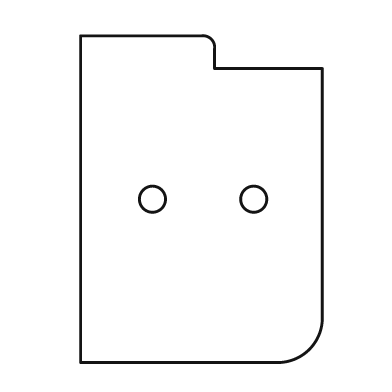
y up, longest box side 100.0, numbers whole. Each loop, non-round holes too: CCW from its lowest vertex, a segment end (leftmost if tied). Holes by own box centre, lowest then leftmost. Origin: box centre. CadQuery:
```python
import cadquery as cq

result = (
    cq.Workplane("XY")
    .moveTo(-37.0, -50.0)
    .lineTo(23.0, -50.0)
    .threePointArc((33.0, -46.0), (37.0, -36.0))
    .lineTo(37.0, 40.0)
    .lineTo(4.0, 40.0)
    .lineTo(4.0, 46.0)
    .threePointArc((3.0, 49.0), (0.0, 50.0))
    .lineTo(-37.0, 50.0)
    .close()
    .moveTo(-15.0, 0.0)
    .circle(4.0)
    .moveTo(16.0, 0.0)
    .circle(4.0)
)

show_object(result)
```